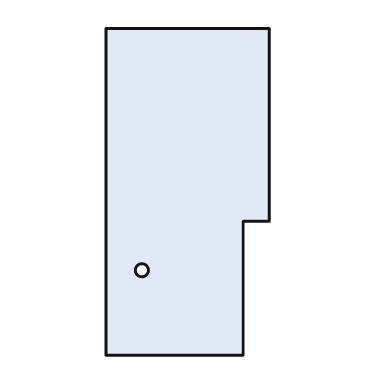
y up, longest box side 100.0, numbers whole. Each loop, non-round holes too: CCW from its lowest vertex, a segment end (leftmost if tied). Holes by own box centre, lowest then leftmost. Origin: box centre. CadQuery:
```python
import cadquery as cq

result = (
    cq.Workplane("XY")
    .moveTo(-25.0, -50.0)
    .lineTo(17.0, -50.0)
    .lineTo(17.0, -9.0)
    .lineTo(25.0, -9.0)
    .lineTo(25.0, 50.0)
    .lineTo(-25.0, 50.0)
    .close()
    .moveTo(-14.0, -24.0)
    .circle(2.0)
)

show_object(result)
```